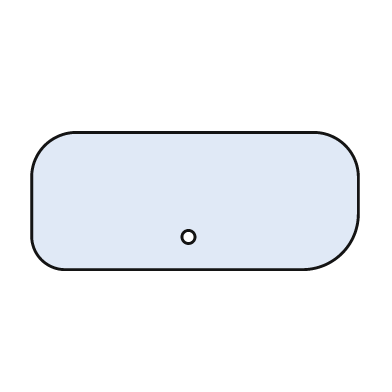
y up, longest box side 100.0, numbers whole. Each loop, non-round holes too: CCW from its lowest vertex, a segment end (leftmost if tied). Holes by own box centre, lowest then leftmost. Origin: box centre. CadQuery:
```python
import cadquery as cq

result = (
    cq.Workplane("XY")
    .moveTo(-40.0, -21.0)
    .lineTo(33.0, -21.0)
    .threePointArc((45.0, -16.0), (50.0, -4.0))
    .lineTo(50.0, 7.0)
    .threePointArc((46.0, 17.0), (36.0, 21.0))
    .lineTo(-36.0, 21.0)
    .threePointArc((-46.0, 17.0), (-50.0, 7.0))
    .lineTo(-50.0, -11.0)
    .threePointArc((-47.0, -18.0), (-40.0, -21.0))
    .close()
    .moveTo(-2.0, -11.0)
    .circle(2.0)
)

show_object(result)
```